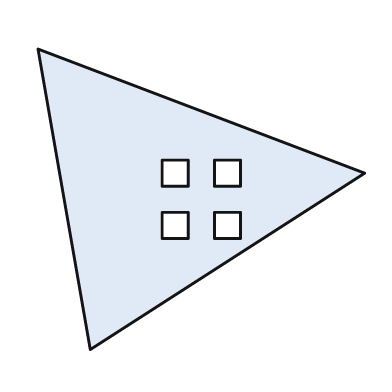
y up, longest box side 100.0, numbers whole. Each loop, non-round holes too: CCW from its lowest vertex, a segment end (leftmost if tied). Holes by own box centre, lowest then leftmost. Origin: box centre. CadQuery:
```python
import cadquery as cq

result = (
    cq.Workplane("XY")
    .moveTo(-34.0, -46.0)
    .lineTo(50.0, 8.0)
    .lineTo(-50.0, 46.0)
    .close()
    .moveTo(-12.0, -12.0)
    .lineTo(-4.0, -12.0)
    .lineTo(-4.0, -4.0)
    .lineTo(-12.0, -4.0)
    .close()
    .moveTo(4.0, -12.0)
    .lineTo(12.0, -12.0)
    .lineTo(12.0, -4.0)
    .lineTo(4.0, -4.0)
    .close()
    .moveTo(-12.0, 4.0)
    .lineTo(-4.0, 4.0)
    .lineTo(-4.0, 12.0)
    .lineTo(-12.0, 12.0)
    .close()
    .moveTo(4.0, 4.0)
    .lineTo(12.0, 4.0)
    .lineTo(12.0, 12.0)
    .lineTo(4.0, 12.0)
    .close()
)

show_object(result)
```